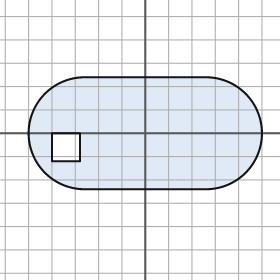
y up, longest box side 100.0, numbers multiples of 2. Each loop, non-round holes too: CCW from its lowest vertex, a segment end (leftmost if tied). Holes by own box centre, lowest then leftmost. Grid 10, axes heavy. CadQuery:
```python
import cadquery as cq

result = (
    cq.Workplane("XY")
    .moveTo(-26.0, -24.0)
    .lineTo(26.0, -24.0)
    .threePointArc((50.0, 0.0), (26.0, 24.0))
    .lineTo(-26.0, 24.0)
    .threePointArc((-50.0, 0.0), (-26.0, -24.0))
    .close()
    .moveTo(-40.0, -12.0)
    .lineTo(-28.0, -12.0)
    .lineTo(-28.0, 0.0)
    .lineTo(-40.0, 0.0)
    .close()
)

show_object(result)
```